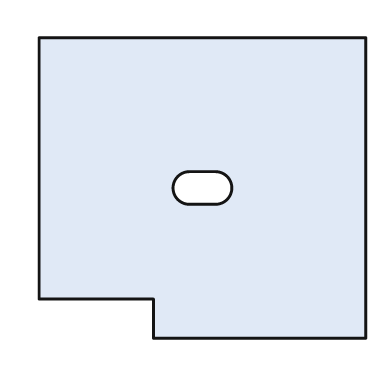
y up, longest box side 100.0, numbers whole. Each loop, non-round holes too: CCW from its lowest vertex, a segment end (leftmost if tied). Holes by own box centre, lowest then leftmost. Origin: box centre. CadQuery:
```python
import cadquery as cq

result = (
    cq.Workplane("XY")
    .moveTo(-15.0, -46.0)
    .lineTo(50.0, -46.0)
    .lineTo(50.0, 46.0)
    .lineTo(-50.0, 46.0)
    .lineTo(-50.0, -34.0)
    .lineTo(-15.0, -34.0)
    .close()
    .moveTo(-4.0, -5.0)
    .lineTo(4.0, -5.0)
    .threePointArc((9.0, 0.0), (4.0, 5.0))
    .lineTo(-4.0, 5.0)
    .threePointArc((-9.0, 0.0), (-4.0, -5.0))
    .close()
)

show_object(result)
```